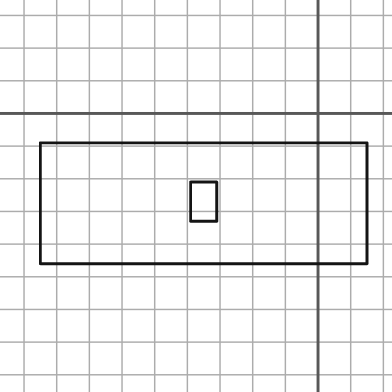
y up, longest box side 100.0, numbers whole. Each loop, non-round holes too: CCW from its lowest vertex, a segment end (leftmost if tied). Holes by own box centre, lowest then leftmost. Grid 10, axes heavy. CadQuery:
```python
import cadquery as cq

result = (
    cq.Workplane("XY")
    .moveTo(-85.0, -46.0)
    .lineTo(15.0, -46.0)
    .lineTo(15.0, -9.0)
    .lineTo(-85.0, -9.0)
    .close()
    .moveTo(-39.0, -33.0)
    .lineTo(-31.0, -33.0)
    .lineTo(-31.0, -21.0)
    .lineTo(-39.0, -21.0)
    .close()
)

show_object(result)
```